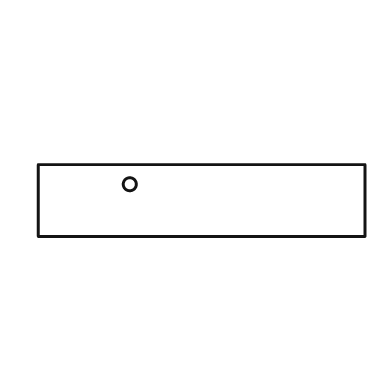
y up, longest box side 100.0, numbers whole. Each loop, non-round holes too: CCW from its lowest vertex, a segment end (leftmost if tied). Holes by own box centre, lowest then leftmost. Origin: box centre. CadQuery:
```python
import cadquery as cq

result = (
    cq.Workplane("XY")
    .moveTo(-50.0, -11.0)
    .lineTo(50.0, -11.0)
    .lineTo(50.0, 11.0)
    .lineTo(-50.0, 11.0)
    .close()
    .moveTo(-22.0, 5.0)
    .circle(2.0)
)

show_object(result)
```